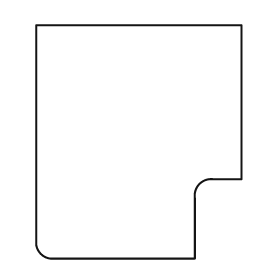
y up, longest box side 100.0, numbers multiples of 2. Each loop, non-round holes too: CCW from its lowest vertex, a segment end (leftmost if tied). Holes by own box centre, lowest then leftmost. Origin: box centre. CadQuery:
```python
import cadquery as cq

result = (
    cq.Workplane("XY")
    .moveTo(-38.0, -50.0)
    .lineTo(24.0, -50.0)
    .lineTo(24.0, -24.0)
    .threePointArc((26.0, -18.0), (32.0, -16.0))
    .lineTo(44.0, -16.0)
    .lineTo(44.0, 50.0)
    .lineTo(-44.0, 50.0)
    .lineTo(-44.0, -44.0)
    .threePointArc((-42.0, -48.0), (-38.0, -50.0))
    .close()
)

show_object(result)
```